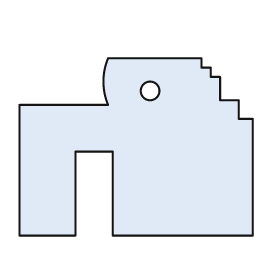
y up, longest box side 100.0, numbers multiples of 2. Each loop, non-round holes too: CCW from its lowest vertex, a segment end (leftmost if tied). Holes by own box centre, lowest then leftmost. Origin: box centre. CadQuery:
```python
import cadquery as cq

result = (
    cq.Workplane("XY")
    .moveTo(-50.0, -38.0)
    .lineTo(-26.0, -38.0)
    .lineTo(-26.0, -2.0)
    .lineTo(-10.0, -2.0)
    .lineTo(-10.0, -38.0)
    .lineTo(50.0, -38.0)
    .lineTo(50.0, 12.0)
    .lineTo(44.0, 12.0)
    .lineTo(44.0, 20.0)
    .lineTo(36.0, 20.0)
    .lineTo(36.0, 30.0)
    .lineTo(32.0, 30.0)
    .lineTo(32.0, 34.0)
    .lineTo(28.0, 34.0)
    .lineTo(28.0, 38.0)
    .lineTo(-12.0, 38.0)
    .threePointArc((-14.0, 28.0), (-12.0, 18.0))
    .lineTo(-50.0, 18.0)
    .close()
    .moveTo(6.0, 24.0)
    .circle(4.0)
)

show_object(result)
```